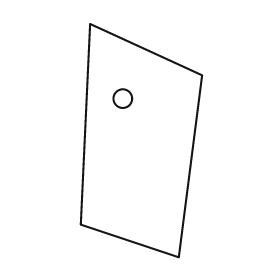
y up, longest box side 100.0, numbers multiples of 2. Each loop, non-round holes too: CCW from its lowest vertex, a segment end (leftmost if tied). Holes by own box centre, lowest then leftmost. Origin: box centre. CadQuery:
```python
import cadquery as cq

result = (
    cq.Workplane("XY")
    .moveTo(16.0, -50.0)
    .lineTo(26.0, 28.0)
    .lineTo(-22.0, 50.0)
    .lineTo(-26.0, -36.0)
    .close()
    .moveTo(-8.0, 18.0)
    .circle(4.0)
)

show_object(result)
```